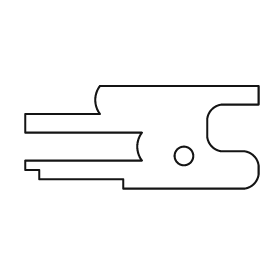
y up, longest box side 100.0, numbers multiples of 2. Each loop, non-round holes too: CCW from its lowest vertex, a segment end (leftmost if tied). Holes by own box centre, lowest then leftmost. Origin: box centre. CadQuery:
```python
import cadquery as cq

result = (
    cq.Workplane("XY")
    .moveTo(-8.0, -22.0)
    .lineTo(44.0, -22.0)
    .threePointArc((48.0, -20.0), (50.0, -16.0))
    .lineTo(50.0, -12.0)
    .threePointArc((48.0, -8.0), (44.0, -6.0))
    .lineTo(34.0, -6.0)
    .threePointArc((30.0, -4.0), (28.0, 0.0))
    .lineTo(28.0, 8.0)
    .threePointArc((30.0, 12.0), (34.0, 14.0))
    .lineTo(50.0, 14.0)
    .lineTo(50.0, 22.0)
    .lineTo(-18.0, 22.0)
    .threePointArc((-20.0, 16.0), (-18.0, 10.0))
    .lineTo(-50.0, 10.0)
    .lineTo(-50.0, 2.0)
    .lineTo(0.0, 2.0)
    .threePointArc((-2.0, -4.0), (0.0, -10.0))
    .lineTo(-50.0, -10.0)
    .lineTo(-50.0, -14.0)
    .lineTo(-44.0, -14.0)
    .lineTo(-44.0, -18.0)
    .lineTo(-8.0, -18.0)
    .close()
    .moveTo(18.0, -8.0)
    .circle(4.0)
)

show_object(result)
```